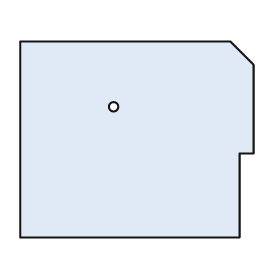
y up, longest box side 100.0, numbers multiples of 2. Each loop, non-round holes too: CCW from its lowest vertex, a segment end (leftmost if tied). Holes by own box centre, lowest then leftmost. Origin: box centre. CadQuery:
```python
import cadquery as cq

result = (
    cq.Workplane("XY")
    .moveTo(-50.0, -42.0)
    .lineTo(44.0, -42.0)
    .lineTo(44.0, -6.0)
    .lineTo(50.0, -6.0)
    .lineTo(50.0, 32.0)
    .lineTo(40.0, 42.0)
    .lineTo(-50.0, 42.0)
    .close()
    .moveTo(-10.0, 14.0)
    .circle(2.0)
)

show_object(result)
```